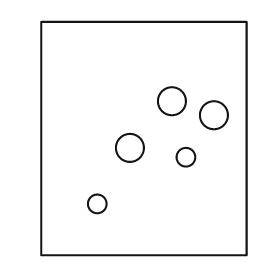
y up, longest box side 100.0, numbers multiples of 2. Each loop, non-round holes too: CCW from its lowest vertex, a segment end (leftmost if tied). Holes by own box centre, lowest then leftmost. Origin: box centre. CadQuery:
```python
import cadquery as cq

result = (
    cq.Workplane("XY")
    .moveTo(-44.0, -50.0)
    .lineTo(44.0, -50.0)
    .lineTo(44.0, 50.0)
    .lineTo(-44.0, 50.0)
    .close()
    .moveTo(-20.0, -28.0)
    .circle(4.0)
    .moveTo(18.0, -8.0)
    .circle(4.0)
    .moveTo(-6.0, -4.0)
    .circle(6.0)
    .moveTo(30.0, 10.0)
    .circle(6.0)
    .moveTo(12.0, 16.0)
    .circle(6.0)
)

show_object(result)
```